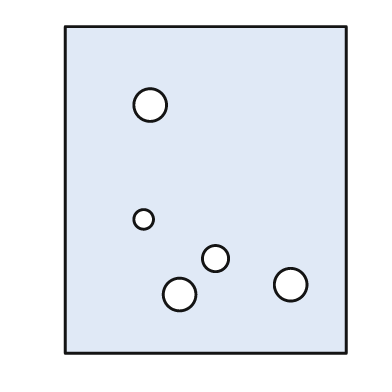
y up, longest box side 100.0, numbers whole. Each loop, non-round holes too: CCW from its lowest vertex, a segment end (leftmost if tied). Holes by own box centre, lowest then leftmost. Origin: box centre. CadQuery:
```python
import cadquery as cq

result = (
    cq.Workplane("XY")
    .moveTo(-43.0, -50.0)
    .lineTo(43.0, -50.0)
    .lineTo(43.0, 50.0)
    .lineTo(-43.0, 50.0)
    .close()
    .moveTo(-8.0, -32.0)
    .circle(5.0)
    .moveTo(26.0, -29.0)
    .circle(5.0)
    .moveTo(3.0, -21.0)
    .circle(4.0)
    .moveTo(-19.0, -9.0)
    .circle(3.0)
    .moveTo(-17.0, 26.0)
    .circle(5.0)
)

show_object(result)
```